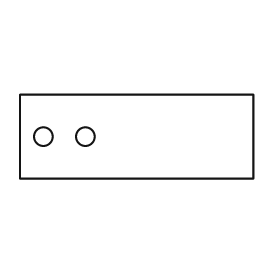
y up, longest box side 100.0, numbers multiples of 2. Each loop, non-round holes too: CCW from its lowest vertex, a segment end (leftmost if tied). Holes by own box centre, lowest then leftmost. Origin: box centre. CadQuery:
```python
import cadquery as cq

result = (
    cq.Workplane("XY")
    .moveTo(-50.0, -18.0)
    .lineTo(50.0, -18.0)
    .lineTo(50.0, 18.0)
    .lineTo(-50.0, 18.0)
    .close()
    .moveTo(-40.0, 0.0)
    .circle(4.0)
    .moveTo(-22.0, 0.0)
    .circle(4.0)
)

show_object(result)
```